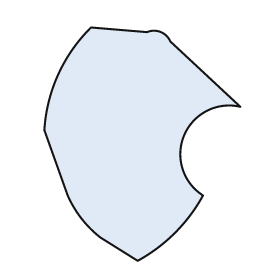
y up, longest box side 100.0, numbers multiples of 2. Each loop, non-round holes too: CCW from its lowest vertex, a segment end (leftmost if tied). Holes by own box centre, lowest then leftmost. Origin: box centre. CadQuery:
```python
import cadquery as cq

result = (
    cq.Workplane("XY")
    .moveTo(-2.0, -50.0)
    .threePointArc((14.0, -38.0), (26.0, -22.0))
    .threePointArc((18.0, 4.0), (42.0, 16.0))
    .lineTo(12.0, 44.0)
    .threePointArc((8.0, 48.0), (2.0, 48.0))
    .lineTo(-22.0, 50.0)
    .threePointArc((-36.0, 30.0), (-42.0, 6.0))
    .lineTo(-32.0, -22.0)
    .threePointArc((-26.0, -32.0), (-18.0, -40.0))
    .close()
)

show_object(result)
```